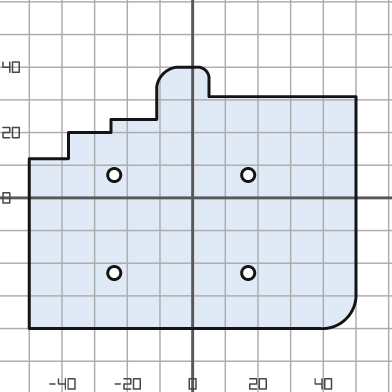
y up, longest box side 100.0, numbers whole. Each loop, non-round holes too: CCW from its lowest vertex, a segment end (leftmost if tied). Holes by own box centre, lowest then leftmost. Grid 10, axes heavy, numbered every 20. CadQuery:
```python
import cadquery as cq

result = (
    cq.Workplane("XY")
    .moveTo(-50.0, -40.0)
    .lineTo(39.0, -40.0)
    .threePointArc((47.0, -37.0), (50.0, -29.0))
    .lineTo(50.0, 31.0)
    .lineTo(5.0, 31.0)
    .lineTo(5.0, 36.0)
    .threePointArc((4.0, 39.0), (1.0, 40.0))
    .lineTo(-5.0, 40.0)
    .threePointArc((-9.0, 38.0), (-11.0, 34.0))
    .lineTo(-11.0, 24.0)
    .lineTo(-25.0, 24.0)
    .lineTo(-25.0, 20.0)
    .lineTo(-38.0, 20.0)
    .lineTo(-38.0, 12.0)
    .lineTo(-50.0, 12.0)
    .close()
    .moveTo(-24.0, -23.0)
    .circle(2.0)
    .moveTo(17.0, -23.0)
    .circle(2.0)
    .moveTo(-24.0, 7.0)
    .circle(2.0)
    .moveTo(17.0, 7.0)
    .circle(2.0)
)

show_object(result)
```